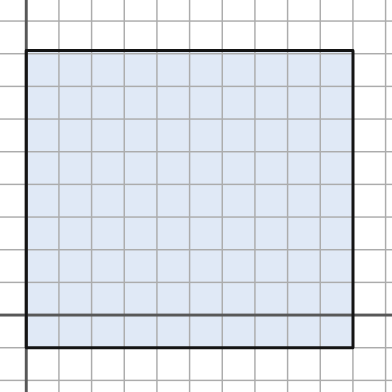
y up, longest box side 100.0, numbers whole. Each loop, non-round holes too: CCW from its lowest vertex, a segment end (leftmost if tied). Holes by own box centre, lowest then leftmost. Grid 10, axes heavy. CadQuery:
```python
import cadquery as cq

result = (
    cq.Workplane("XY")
    .moveTo(0.0, -10.0)
    .lineTo(100.0, -10.0)
    .lineTo(100.0, 81.0)
    .lineTo(0.0, 81.0)
    .close()
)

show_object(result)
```